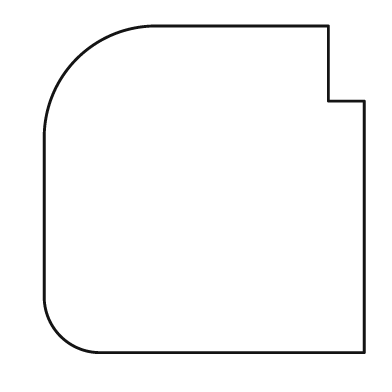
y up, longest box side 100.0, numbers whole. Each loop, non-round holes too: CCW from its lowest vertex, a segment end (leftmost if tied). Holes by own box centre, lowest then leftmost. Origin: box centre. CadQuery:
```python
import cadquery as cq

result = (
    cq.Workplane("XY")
    .moveTo(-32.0, -50.0)
    .lineTo(49.0, -50.0)
    .lineTo(49.0, 27.0)
    .lineTo(38.0, 27.0)
    .lineTo(38.0, 50.0)
    .lineTo(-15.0, 50.0)
    .threePointArc((-39.0, 40.0), (-49.0, 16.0))
    .lineTo(-49.0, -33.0)
    .threePointArc((-44.0, -45.0), (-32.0, -50.0))
    .close()
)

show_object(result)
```